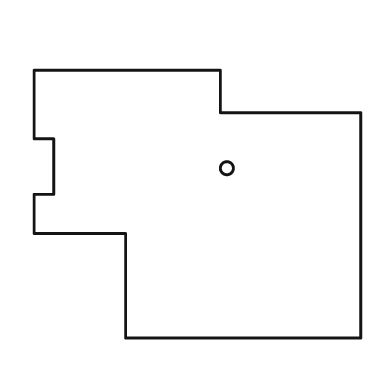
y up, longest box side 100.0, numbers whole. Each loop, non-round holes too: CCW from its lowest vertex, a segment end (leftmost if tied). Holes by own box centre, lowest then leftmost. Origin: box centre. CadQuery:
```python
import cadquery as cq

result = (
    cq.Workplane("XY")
    .moveTo(-22.0, -41.0)
    .lineTo(50.0, -41.0)
    .lineTo(50.0, 28.0)
    .lineTo(7.0, 28.0)
    .lineTo(7.0, 41.0)
    .lineTo(-50.0, 41.0)
    .lineTo(-50.0, 20.0)
    .lineTo(-44.0, 20.0)
    .lineTo(-44.0, 3.0)
    .lineTo(-50.0, 3.0)
    .lineTo(-50.0, -9.0)
    .lineTo(-22.0, -9.0)
    .close()
    .moveTo(9.0, 11.0)
    .circle(2.0)
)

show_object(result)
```